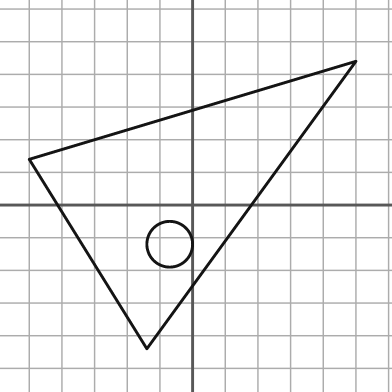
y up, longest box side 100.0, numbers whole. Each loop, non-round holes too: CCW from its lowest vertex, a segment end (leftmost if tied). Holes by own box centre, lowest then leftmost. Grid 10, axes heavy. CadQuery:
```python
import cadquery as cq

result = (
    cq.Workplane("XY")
    .moveTo(-14.0, -44.0)
    .lineTo(50.0, 44.0)
    .lineTo(-50.0, 14.0)
    .close()
    .moveTo(-7.0, -12.0)
    .circle(7.0)
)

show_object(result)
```